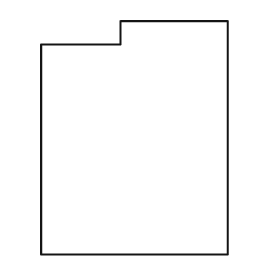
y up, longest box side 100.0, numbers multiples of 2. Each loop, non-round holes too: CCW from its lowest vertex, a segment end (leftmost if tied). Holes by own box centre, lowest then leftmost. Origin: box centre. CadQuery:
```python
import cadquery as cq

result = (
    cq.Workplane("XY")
    .moveTo(-40.0, -50.0)
    .lineTo(40.0, -50.0)
    .lineTo(40.0, 50.0)
    .lineTo(-6.0, 50.0)
    .lineTo(-6.0, 40.0)
    .lineTo(-40.0, 40.0)
    .close()
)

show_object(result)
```